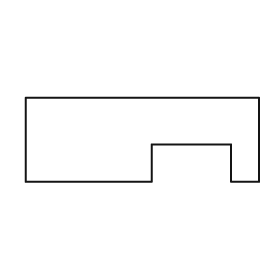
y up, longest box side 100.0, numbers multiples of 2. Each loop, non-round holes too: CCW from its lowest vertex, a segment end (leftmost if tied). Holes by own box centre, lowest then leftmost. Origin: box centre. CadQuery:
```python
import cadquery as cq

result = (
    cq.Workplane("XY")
    .moveTo(-50.0, -18.0)
    .lineTo(4.0, -18.0)
    .lineTo(4.0, -2.0)
    .lineTo(38.0, -2.0)
    .lineTo(38.0, -18.0)
    .lineTo(50.0, -18.0)
    .lineTo(50.0, 18.0)
    .lineTo(-50.0, 18.0)
    .close()
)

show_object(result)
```